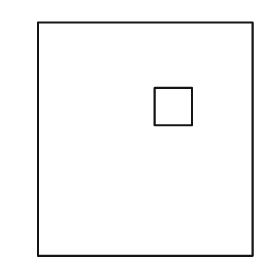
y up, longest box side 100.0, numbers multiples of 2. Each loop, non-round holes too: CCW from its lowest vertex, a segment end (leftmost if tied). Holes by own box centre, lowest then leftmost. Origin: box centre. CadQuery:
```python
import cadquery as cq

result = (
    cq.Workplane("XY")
    .moveTo(-46.0, -50.0)
    .lineTo(46.0, -50.0)
    .lineTo(46.0, 50.0)
    .lineTo(-46.0, 50.0)
    .close()
    .moveTo(4.0, 6.0)
    .lineTo(20.0, 6.0)
    .lineTo(20.0, 22.0)
    .lineTo(4.0, 22.0)
    .close()
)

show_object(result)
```